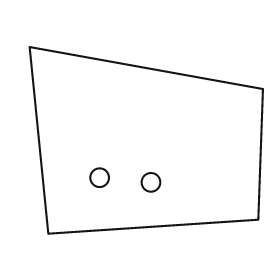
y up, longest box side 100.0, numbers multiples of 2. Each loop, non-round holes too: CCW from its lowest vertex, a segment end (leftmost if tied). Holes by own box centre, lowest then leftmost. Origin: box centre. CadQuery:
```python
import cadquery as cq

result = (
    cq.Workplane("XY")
    .moveTo(-42.0, -40.0)
    .lineTo(48.0, -34.0)
    .lineTo(50.0, 22.0)
    .lineTo(-50.0, 40.0)
    .close()
    .moveTo(2.0, -18.0)
    .circle(4.0)
    .moveTo(-20.0, -16.0)
    .circle(4.0)
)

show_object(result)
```